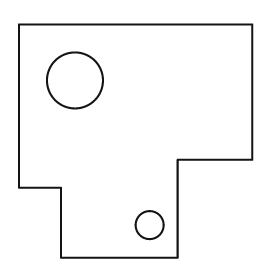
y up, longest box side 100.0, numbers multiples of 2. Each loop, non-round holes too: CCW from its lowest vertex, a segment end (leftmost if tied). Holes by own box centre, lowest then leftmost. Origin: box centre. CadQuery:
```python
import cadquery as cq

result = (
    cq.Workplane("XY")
    .moveTo(-32.0, -50.0)
    .lineTo(18.0, -50.0)
    .lineTo(18.0, -8.0)
    .lineTo(50.0, -8.0)
    .lineTo(50.0, 50.0)
    .lineTo(-50.0, 50.0)
    .lineTo(-50.0, -20.0)
    .lineTo(-32.0, -20.0)
    .close()
    .moveTo(6.0, -36.0)
    .circle(6.0)
    .moveTo(-26.0, 26.0)
    .circle(12.0)
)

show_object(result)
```